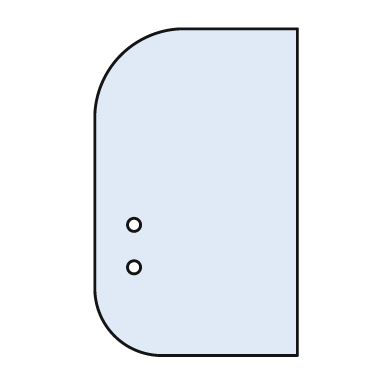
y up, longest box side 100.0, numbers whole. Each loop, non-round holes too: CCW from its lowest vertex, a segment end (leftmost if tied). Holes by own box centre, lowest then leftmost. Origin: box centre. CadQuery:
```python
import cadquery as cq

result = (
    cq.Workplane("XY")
    .moveTo(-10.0, -50.0)
    .lineTo(31.0, -50.0)
    .lineTo(31.0, 50.0)
    .lineTo(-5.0, 50.0)
    .threePointArc((-23.0, 42.0), (-31.0, 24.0))
    .lineTo(-31.0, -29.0)
    .threePointArc((-25.0, -44.0), (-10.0, -50.0))
    .close()
    .moveTo(-19.0, -23.0)
    .circle(2.0)
    .moveTo(-19.0, -10.0)
    .circle(2.0)
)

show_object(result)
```